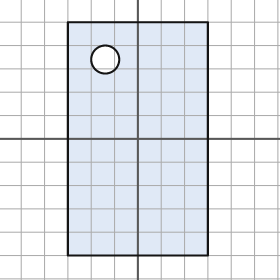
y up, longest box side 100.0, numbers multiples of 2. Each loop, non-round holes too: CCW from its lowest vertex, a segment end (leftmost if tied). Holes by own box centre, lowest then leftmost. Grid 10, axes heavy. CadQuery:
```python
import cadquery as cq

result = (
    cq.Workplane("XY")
    .moveTo(-30.0, -50.0)
    .lineTo(30.0, -50.0)
    .lineTo(30.0, 50.0)
    .lineTo(-30.0, 50.0)
    .close()
    .moveTo(-14.0, 34.0)
    .circle(6.0)
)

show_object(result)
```